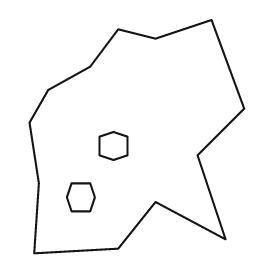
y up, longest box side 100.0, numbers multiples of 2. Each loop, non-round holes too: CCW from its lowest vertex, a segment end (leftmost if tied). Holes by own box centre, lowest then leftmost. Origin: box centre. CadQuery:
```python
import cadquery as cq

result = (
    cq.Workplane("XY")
    .moveTo(-44.0, -50.0)
    .lineTo(-8.0, -48.0)
    .lineTo(8.0, -28.0)
    .lineTo(38.0, -44.0)
    .lineTo(26.0, -8.0)
    .lineTo(46.0, 12.0)
    .lineTo(32.0, 50.0)
    .lineTo(8.0, 42.0)
    .lineTo(-8.0, 46.0)
    .lineTo(-20.0, 30.0)
    .lineTo(-38.0, 20.0)
    .lineTo(-46.0, 6.0)
    .lineTo(-42.0, -20.0)
    .close()
    .moveTo(-28.0, -32.0)
    .lineTo(-20.0, -32.0)
    .lineTo(-18.0, -26.0)
    .lineTo(-20.0, -20.0)
    .lineTo(-28.0, -20.0)
    .lineTo(-30.0, -26.0)
    .close()
    .moveTo(-10.0, -10.0)
    .lineTo(-4.0, -8.0)
    .lineTo(-4.0, 0.0)
    .lineTo(-10.0, 2.0)
    .lineTo(-16.0, 0.0)
    .lineTo(-16.0, -8.0)
    .close()
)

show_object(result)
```